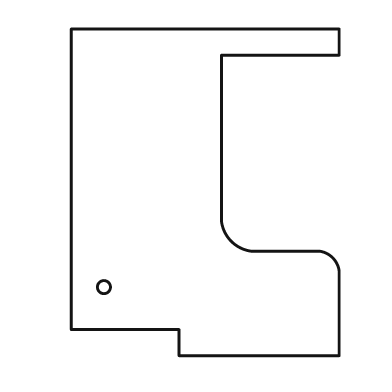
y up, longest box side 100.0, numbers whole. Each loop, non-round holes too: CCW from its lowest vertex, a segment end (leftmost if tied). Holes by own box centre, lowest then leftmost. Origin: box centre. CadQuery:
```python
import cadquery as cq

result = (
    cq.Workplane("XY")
    .moveTo(-8.0, -50.0)
    .lineTo(41.0, -50.0)
    .lineTo(41.0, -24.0)
    .threePointArc((39.0, -20.0), (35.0, -18.0))
    .lineTo(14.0, -18.0)
    .threePointArc((8.0, -15.0), (5.0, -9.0))
    .lineTo(5.0, 42.0)
    .lineTo(41.0, 42.0)
    .lineTo(41.0, 50.0)
    .lineTo(-41.0, 50.0)
    .lineTo(-41.0, -42.0)
    .lineTo(-8.0, -42.0)
    .close()
    .moveTo(-31.0, -29.0)
    .circle(2.0)
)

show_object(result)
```